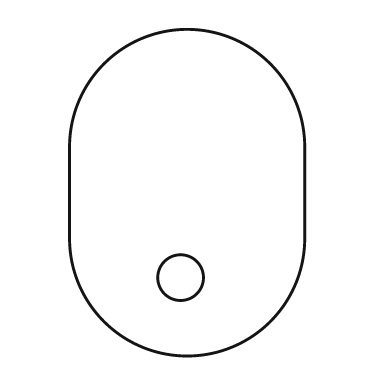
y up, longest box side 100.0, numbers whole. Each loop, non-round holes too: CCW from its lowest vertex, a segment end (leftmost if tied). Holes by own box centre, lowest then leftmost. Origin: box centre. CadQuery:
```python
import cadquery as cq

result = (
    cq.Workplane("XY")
    .moveTo(-36.0, -14.0)
    .threePointArc((0.0, -50.0), (36.0, -14.0))
    .lineTo(36.0, 14.0)
    .threePointArc((0.0, 50.0), (-36.0, 14.0))
    .close()
    .moveTo(-2.0, -26.0)
    .circle(7.0)
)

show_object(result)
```